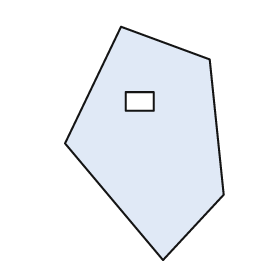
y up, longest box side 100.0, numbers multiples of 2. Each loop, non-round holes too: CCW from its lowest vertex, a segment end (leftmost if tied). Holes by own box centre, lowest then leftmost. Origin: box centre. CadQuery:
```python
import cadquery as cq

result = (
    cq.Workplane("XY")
    .moveTo(8.0, -50.0)
    .lineTo(34.0, -22.0)
    .lineTo(28.0, 36.0)
    .lineTo(-10.0, 50.0)
    .lineTo(-34.0, 0.0)
    .close()
    .moveTo(-8.0, 14.0)
    .lineTo(4.0, 14.0)
    .lineTo(4.0, 22.0)
    .lineTo(-8.0, 22.0)
    .close()
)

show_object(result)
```